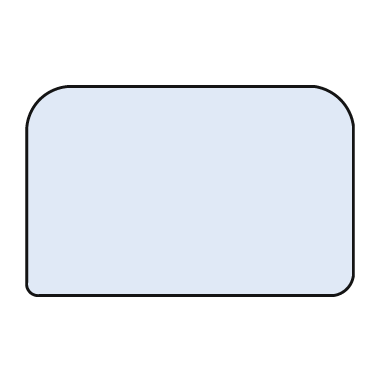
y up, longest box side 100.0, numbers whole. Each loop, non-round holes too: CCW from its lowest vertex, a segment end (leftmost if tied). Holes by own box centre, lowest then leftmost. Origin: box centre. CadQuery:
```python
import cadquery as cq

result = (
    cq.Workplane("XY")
    .moveTo(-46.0, -32.0)
    .lineTo(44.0, -32.0)
    .threePointArc((48.0, -30.0), (50.0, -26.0))
    .lineTo(50.0, 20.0)
    .threePointArc((46.0, 28.0), (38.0, 32.0))
    .lineTo(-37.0, 32.0)
    .threePointArc((-46.0, 28.0), (-50.0, 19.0))
    .lineTo(-50.0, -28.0)
    .threePointArc((-49.0, -31.0), (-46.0, -32.0))
    .close()
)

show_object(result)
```